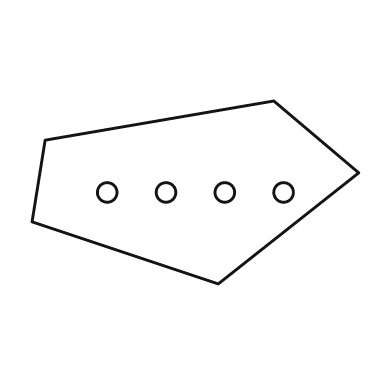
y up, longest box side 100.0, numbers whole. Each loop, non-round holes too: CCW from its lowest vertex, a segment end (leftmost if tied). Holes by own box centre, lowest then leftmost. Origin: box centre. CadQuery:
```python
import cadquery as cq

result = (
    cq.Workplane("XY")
    .moveTo(7.0, -28.0)
    .lineTo(50.0, 6.0)
    .lineTo(24.0, 28.0)
    .lineTo(-46.0, 16.0)
    .lineTo(-50.0, -9.0)
    .close()
    .moveTo(-27.0, 0.0)
    .circle(3.0)
    .moveTo(-9.0, 0.0)
    .circle(3.0)
    .moveTo(9.0, 0.0)
    .circle(3.0)
    .moveTo(27.0, 0.0)
    .circle(3.0)
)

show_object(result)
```